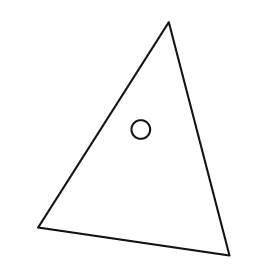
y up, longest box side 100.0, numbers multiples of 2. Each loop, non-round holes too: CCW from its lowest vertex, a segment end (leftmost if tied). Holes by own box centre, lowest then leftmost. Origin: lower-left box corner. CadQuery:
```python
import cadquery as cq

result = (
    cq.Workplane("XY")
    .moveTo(82.0, 0.0)
    .lineTo(56.0, 100.0)
    .lineTo(0.0, 12.0)
    .close()
    .moveTo(44.0, 54.0)
    .circle(4.0)
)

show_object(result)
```